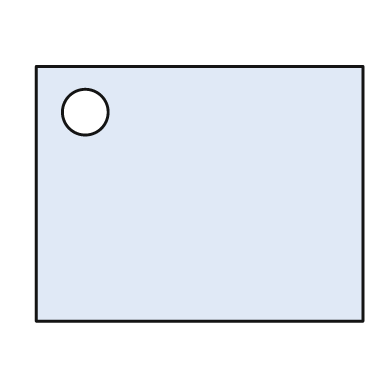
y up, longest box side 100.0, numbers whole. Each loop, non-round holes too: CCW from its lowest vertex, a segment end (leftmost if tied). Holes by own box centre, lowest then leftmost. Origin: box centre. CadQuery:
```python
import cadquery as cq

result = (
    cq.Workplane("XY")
    .moveTo(-50.0, -39.0)
    .lineTo(50.0, -39.0)
    .lineTo(50.0, 39.0)
    .lineTo(-50.0, 39.0)
    .close()
    .moveTo(-35.0, 25.0)
    .circle(7.0)
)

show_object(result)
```